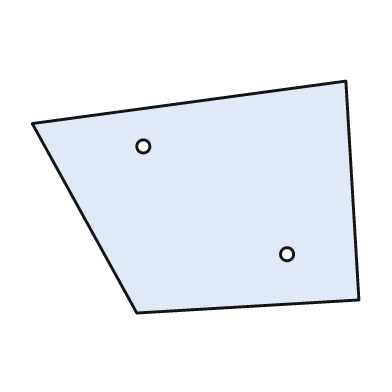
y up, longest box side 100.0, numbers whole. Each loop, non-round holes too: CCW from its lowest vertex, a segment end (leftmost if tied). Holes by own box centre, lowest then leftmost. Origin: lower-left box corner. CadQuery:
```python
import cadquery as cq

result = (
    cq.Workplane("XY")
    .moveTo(32.0, 0.0)
    .lineTo(100.0, 4.0)
    .lineTo(96.0, 71.0)
    .lineTo(0.0, 58.0)
    .close()
    .moveTo(78.0, 18.0)
    .circle(2.0)
    .moveTo(34.0, 51.0)
    .circle(2.0)
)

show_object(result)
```